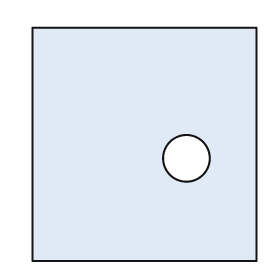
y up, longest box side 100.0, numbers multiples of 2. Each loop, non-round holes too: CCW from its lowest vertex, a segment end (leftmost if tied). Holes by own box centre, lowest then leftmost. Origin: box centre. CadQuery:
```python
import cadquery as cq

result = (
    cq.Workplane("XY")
    .moveTo(-48.0, -50.0)
    .lineTo(48.0, -50.0)
    .lineTo(48.0, 50.0)
    .lineTo(-48.0, 50.0)
    .close()
    .moveTo(18.0, -6.0)
    .circle(10.0)
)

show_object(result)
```